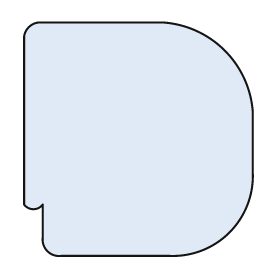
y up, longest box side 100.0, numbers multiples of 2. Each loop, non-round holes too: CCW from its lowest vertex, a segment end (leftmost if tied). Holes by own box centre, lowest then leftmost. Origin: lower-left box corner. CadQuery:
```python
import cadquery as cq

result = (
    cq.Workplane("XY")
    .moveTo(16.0, 0.0)
    .lineTo(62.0, 0.0)
    .threePointArc((88.0, 10.0), (98.0, 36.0))
    .lineTo(98.0, 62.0)
    .threePointArc((86.0, 88.0), (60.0, 100.0))
    .lineTo(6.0, 100.0)
    .threePointArc((2.0, 98.0), (0.0, 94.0))
    .lineTo(0.0, 22.0)
    .threePointArc((4.0, 20.0), (8.0, 22.0))
    .lineTo(8.0, 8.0)
    .threePointArc((10.0, 2.0), (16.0, 0.0))
    .close()
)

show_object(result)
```